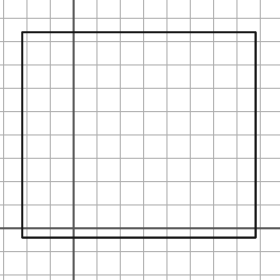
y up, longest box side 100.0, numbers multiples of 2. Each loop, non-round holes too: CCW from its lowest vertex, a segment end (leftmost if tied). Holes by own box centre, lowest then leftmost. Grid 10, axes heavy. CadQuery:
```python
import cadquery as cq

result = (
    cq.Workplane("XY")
    .moveTo(-22.0, -4.0)
    .lineTo(78.0, -4.0)
    .lineTo(78.0, 84.0)
    .lineTo(-22.0, 84.0)
    .close()
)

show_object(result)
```